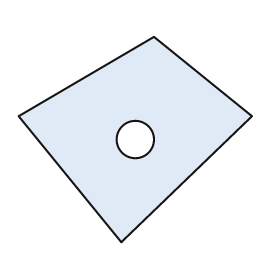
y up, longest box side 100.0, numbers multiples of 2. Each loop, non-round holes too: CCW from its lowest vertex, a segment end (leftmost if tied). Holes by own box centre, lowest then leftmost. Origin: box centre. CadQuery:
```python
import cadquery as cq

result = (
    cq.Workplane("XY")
    .moveTo(-6.0, -44.0)
    .lineTo(50.0, 10.0)
    .lineTo(8.0, 44.0)
    .lineTo(-50.0, 10.0)
    .close()
    .moveTo(0.0, 0.0)
    .circle(8.0)
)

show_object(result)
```